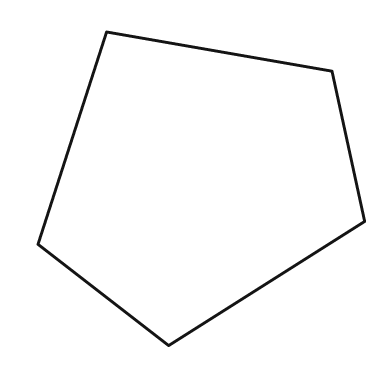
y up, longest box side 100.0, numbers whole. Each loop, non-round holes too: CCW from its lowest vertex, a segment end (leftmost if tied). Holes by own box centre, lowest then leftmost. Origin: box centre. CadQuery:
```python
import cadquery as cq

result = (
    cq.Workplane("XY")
    .moveTo(-10.0, -48.0)
    .lineTo(50.0, -10.0)
    .lineTo(40.0, 36.0)
    .lineTo(-29.0, 48.0)
    .lineTo(-50.0, -17.0)
    .close()
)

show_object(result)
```